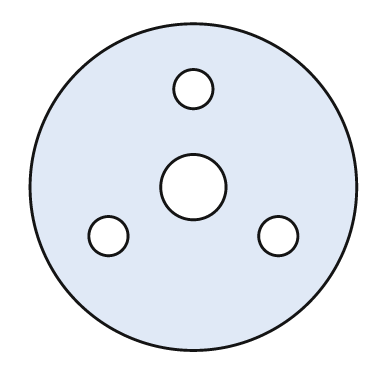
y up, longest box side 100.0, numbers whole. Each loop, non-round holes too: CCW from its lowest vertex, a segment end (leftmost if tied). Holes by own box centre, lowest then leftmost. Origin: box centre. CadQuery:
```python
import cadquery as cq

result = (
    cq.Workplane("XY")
    .moveTo(0.0, 0.0)
    .circle(50.0)
    .moveTo(-26.0, -15.0)
    .circle(6.0)
    .moveTo(26.0, -15.0)
    .circle(6.0)
    .moveTo(0.0, 0.0)
    .circle(10.0)
    .moveTo(0.0, 30.0)
    .circle(6.0)
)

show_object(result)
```